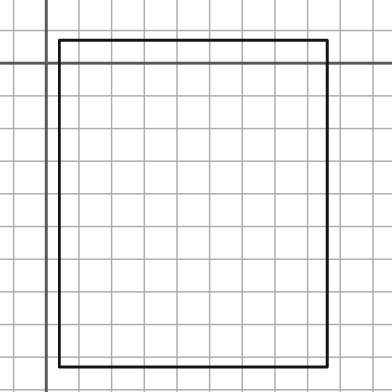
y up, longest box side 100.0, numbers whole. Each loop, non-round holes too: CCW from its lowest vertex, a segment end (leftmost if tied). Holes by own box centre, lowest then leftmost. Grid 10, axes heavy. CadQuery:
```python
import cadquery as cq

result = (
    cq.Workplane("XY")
    .moveTo(4.0, -93.0)
    .lineTo(86.0, -93.0)
    .lineTo(86.0, 7.0)
    .lineTo(4.0, 7.0)
    .close()
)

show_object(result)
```